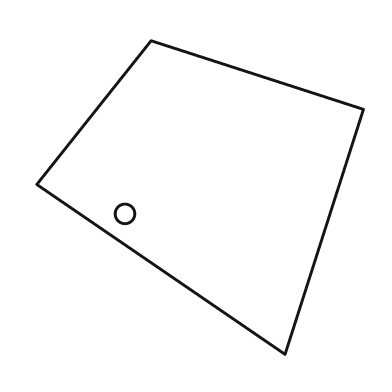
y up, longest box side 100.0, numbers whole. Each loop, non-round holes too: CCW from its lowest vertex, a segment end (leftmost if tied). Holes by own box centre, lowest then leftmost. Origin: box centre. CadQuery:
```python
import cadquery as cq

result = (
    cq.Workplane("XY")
    .moveTo(26.0, -48.0)
    .lineTo(50.0, 27.0)
    .lineTo(-15.0, 48.0)
    .lineTo(-50.0, 4.0)
    .close()
    .moveTo(-23.0, -5.0)
    .circle(3.0)
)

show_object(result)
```